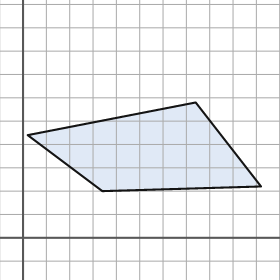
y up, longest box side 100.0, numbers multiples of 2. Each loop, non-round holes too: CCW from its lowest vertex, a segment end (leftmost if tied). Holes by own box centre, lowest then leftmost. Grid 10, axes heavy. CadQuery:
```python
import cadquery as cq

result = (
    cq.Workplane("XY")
    .moveTo(34.0, 20.0)
    .lineTo(102.0, 22.0)
    .lineTo(74.0, 58.0)
    .lineTo(2.0, 44.0)
    .close()
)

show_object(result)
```